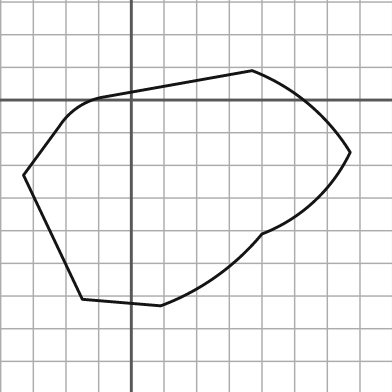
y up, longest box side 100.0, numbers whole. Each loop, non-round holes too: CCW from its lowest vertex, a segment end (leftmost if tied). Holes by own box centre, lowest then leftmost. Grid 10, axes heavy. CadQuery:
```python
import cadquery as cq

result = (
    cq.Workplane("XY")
    .moveTo(9.0, -63.0)
    .threePointArc((26.0, -54.0), (40.0, -41.0))
    .threePointArc((56.0, -31.0), (67.0, -16.0))
    .threePointArc((54.0, -1.0), (37.0, 9.0))
    .lineTo(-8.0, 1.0)
    .threePointArc((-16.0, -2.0), (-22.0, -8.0))
    .lineTo(-33.0, -23.0)
    .lineTo(-15.0, -61.0)
    .close()
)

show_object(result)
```